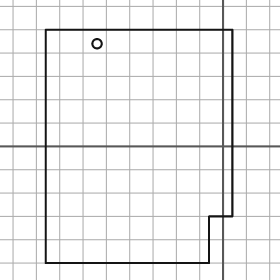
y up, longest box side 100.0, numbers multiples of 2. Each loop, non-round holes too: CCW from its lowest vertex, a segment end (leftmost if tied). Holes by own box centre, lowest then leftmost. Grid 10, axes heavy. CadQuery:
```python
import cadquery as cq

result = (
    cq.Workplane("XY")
    .moveTo(-76.0, -50.0)
    .lineTo(-6.0, -50.0)
    .lineTo(-6.0, -30.0)
    .lineTo(4.0, -30.0)
    .lineTo(4.0, 50.0)
    .lineTo(-76.0, 50.0)
    .close()
    .moveTo(-54.0, 44.0)
    .circle(2.0)
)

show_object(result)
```